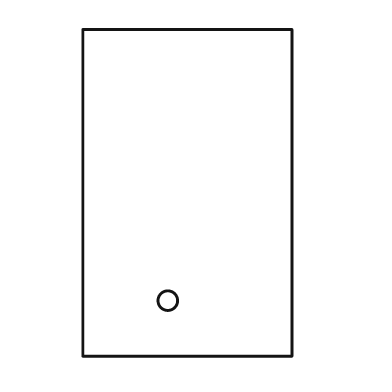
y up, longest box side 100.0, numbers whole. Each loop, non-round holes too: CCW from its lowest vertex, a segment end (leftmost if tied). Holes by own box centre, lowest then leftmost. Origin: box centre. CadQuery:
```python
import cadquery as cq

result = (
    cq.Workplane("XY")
    .moveTo(-32.0, -50.0)
    .lineTo(32.0, -50.0)
    .lineTo(32.0, 50.0)
    .lineTo(-32.0, 50.0)
    .close()
    .moveTo(-6.0, -33.0)
    .circle(3.0)
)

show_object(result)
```